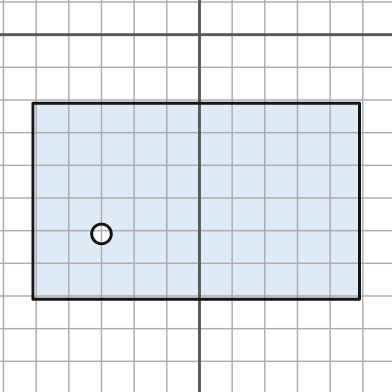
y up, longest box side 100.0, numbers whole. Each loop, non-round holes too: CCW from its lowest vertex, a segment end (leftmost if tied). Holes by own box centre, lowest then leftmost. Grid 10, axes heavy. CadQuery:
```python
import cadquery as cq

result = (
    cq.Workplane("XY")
    .moveTo(-51.0, -81.0)
    .lineTo(49.0, -81.0)
    .lineTo(49.0, -21.0)
    .lineTo(-51.0, -21.0)
    .close()
    .moveTo(-30.0, -61.0)
    .circle(3.0)
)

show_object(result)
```